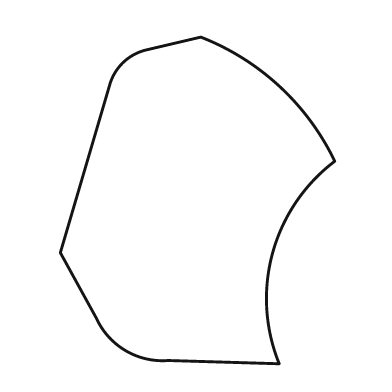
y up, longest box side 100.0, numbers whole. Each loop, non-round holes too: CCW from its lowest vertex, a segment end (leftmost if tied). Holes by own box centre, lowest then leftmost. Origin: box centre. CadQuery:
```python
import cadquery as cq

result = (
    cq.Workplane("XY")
    .moveTo(25.0, -50.0)
    .threePointArc((23.0, -16.0), (42.0, 12.0))
    .threePointArc((25.0, 35.0), (1.0, 50.0))
    .lineTo(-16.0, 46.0)
    .threePointArc((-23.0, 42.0), (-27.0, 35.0))
    .lineTo(-42.0, -16.0)
    .lineTo(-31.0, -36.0)
    .threePointArc((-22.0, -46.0), (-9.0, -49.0))
    .close()
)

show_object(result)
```